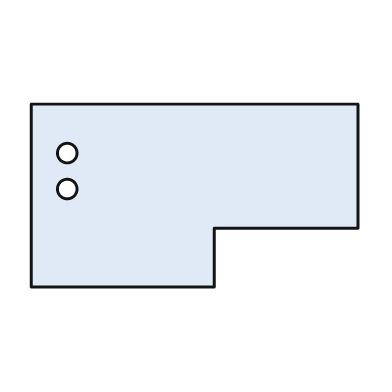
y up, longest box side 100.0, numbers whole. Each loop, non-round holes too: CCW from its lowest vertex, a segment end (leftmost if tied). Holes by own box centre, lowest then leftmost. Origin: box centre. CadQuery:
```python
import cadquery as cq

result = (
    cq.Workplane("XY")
    .moveTo(-50.0, -28.0)
    .lineTo(6.0, -28.0)
    .lineTo(6.0, -10.0)
    .lineTo(50.0, -10.0)
    .lineTo(50.0, 28.0)
    .lineTo(-50.0, 28.0)
    .close()
    .moveTo(-39.0, 2.0)
    .circle(3.0)
    .moveTo(-39.0, 13.0)
    .circle(3.0)
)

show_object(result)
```